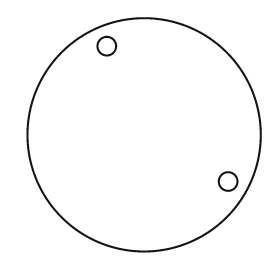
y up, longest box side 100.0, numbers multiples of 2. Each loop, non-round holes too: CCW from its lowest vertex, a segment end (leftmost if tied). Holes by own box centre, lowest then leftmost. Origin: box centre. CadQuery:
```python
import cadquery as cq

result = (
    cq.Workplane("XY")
    .moveTo(0.0, 0.0)
    .circle(50.0)
    .moveTo(36.0, -20.0)
    .circle(4.0)
    .moveTo(-16.0, 38.0)
    .circle(4.0)
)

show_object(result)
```